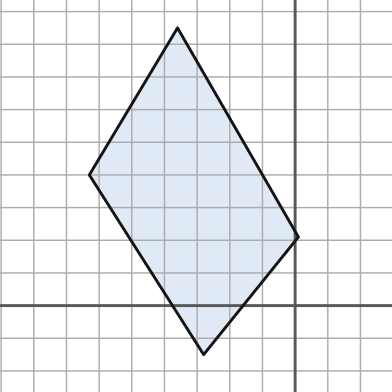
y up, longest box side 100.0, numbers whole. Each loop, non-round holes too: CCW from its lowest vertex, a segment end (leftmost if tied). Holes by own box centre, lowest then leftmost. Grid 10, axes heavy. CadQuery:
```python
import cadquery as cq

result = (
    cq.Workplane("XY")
    .moveTo(-28.0, -15.0)
    .lineTo(1.0, 21.0)
    .lineTo(-36.0, 85.0)
    .lineTo(-63.0, 40.0)
    .close()
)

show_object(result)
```